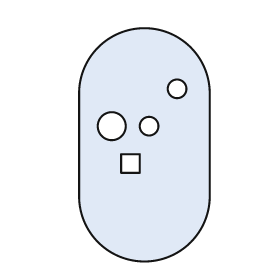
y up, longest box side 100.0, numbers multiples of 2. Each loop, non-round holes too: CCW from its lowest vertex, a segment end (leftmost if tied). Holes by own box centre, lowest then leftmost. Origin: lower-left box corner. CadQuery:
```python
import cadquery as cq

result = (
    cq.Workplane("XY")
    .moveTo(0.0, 28.0)
    .threePointArc((28.0, 0.0), (56.0, 28.0))
    .lineTo(56.0, 72.0)
    .threePointArc((28.0, 100.0), (0.0, 72.0))
    .close()
    .moveTo(18.0, 38.0)
    .lineTo(26.0, 38.0)
    .lineTo(26.0, 46.0)
    .lineTo(18.0, 46.0)
    .close()
    .moveTo(14.0, 58.0)
    .circle(6.0)
    .moveTo(30.0, 58.0)
    .circle(4.0)
    .moveTo(42.0, 74.0)
    .circle(4.0)
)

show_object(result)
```